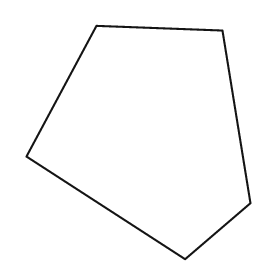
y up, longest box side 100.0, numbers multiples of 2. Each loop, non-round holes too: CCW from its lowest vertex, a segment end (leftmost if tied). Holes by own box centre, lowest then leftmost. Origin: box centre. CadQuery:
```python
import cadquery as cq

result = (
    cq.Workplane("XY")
    .moveTo(20.0, -50.0)
    .lineTo(48.0, -26.0)
    .lineTo(36.0, 48.0)
    .lineTo(-18.0, 50.0)
    .lineTo(-48.0, -6.0)
    .close()
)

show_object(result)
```